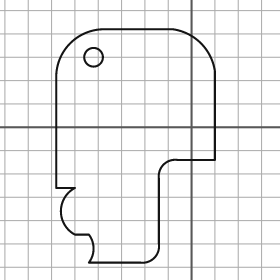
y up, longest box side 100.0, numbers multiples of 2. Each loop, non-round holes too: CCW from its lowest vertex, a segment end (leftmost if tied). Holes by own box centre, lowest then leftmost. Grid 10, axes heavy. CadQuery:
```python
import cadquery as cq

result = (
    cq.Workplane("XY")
    .moveTo(-44.0, -58.0)
    .lineTo(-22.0, -58.0)
    .threePointArc((-16.0, -56.0), (-14.0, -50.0))
    .lineTo(-14.0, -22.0)
    .threePointArc((-12.0, -16.0), (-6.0, -14.0))
    .lineTo(10.0, -14.0)
    .lineTo(10.0, 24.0)
    .threePointArc((4.0, 36.0), (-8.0, 42.0))
    .lineTo(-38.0, 42.0)
    .threePointArc((-52.0, 36.0), (-58.0, 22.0))
    .lineTo(-58.0, -26.0)
    .lineTo(-50.0, -26.0)
    .threePointArc((-56.0, -36.0), (-50.0, -46.0))
    .lineTo(-44.0, -46.0)
    .threePointArc((-42.0, -52.0), (-44.0, -58.0))
    .close()
    .moveTo(-42.0, 30.0)
    .circle(4.0)
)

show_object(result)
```